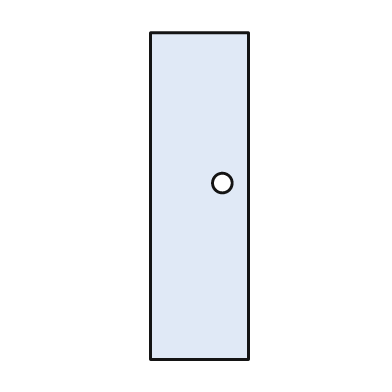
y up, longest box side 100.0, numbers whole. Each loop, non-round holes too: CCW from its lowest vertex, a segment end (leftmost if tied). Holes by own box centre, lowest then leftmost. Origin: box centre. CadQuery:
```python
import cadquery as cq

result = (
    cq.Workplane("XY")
    .moveTo(-15.0, -50.0)
    .lineTo(15.0, -50.0)
    .lineTo(15.0, 50.0)
    .lineTo(-15.0, 50.0)
    .close()
    .moveTo(7.0, 4.0)
    .circle(3.0)
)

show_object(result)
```